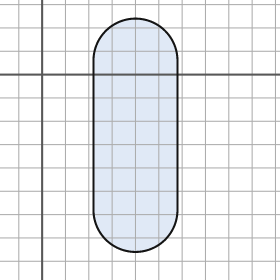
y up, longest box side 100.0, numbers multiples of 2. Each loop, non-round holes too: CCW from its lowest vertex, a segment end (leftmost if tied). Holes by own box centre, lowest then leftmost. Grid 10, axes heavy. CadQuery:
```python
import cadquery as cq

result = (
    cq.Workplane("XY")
    .moveTo(22.0, -58.0)
    .threePointArc((40.0, -76.0), (58.0, -58.0))
    .lineTo(58.0, 6.0)
    .threePointArc((40.0, 24.0), (22.0, 6.0))
    .close()
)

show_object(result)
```